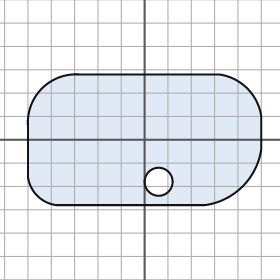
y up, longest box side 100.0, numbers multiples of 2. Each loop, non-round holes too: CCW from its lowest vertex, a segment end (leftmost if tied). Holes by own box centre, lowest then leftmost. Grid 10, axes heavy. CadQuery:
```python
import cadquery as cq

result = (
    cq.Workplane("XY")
    .moveTo(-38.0, -28.0)
    .lineTo(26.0, -28.0)
    .threePointArc((42.0, -20.0), (50.0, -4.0))
    .lineTo(50.0, 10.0)
    .threePointArc((44.0, 22.0), (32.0, 28.0))
    .lineTo(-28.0, 28.0)
    .threePointArc((-44.0, 22.0), (-50.0, 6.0))
    .lineTo(-50.0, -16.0)
    .threePointArc((-46.0, -24.0), (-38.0, -28.0))
    .close()
    .moveTo(6.0, -18.0)
    .circle(6.0)
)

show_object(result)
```